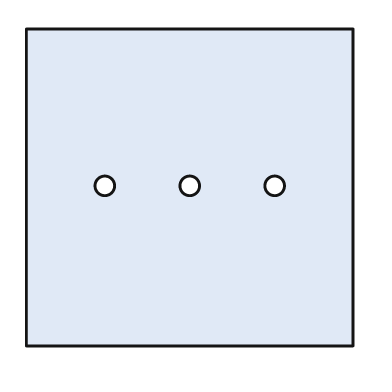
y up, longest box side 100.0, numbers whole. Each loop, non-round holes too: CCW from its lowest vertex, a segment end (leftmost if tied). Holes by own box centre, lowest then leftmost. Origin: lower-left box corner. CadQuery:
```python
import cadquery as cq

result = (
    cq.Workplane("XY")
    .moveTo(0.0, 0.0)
    .lineTo(100.0, 0.0)
    .lineTo(100.0, 97.0)
    .lineTo(0.0, 97.0)
    .close()
    .moveTo(24.0, 49.0)
    .circle(3.0)
    .moveTo(50.0, 49.0)
    .circle(3.0)
    .moveTo(76.0, 49.0)
    .circle(3.0)
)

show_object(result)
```